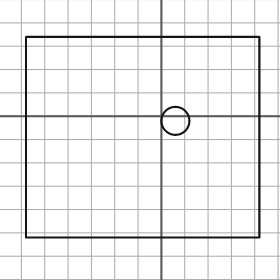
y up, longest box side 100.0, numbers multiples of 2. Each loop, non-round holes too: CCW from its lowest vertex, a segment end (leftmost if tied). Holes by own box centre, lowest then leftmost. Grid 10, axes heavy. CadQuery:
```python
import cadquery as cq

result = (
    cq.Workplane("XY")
    .moveTo(-58.0, -52.0)
    .lineTo(42.0, -52.0)
    .lineTo(42.0, 34.0)
    .lineTo(-58.0, 34.0)
    .close()
    .moveTo(6.0, -2.0)
    .circle(6.0)
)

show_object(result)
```